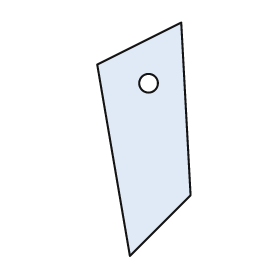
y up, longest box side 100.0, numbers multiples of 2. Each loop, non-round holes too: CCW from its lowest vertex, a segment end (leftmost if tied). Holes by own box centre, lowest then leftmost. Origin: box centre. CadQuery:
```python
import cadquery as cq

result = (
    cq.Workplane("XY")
    .moveTo(-6.0, -50.0)
    .lineTo(20.0, -24.0)
    .lineTo(16.0, 50.0)
    .lineTo(-20.0, 32.0)
    .close()
    .moveTo(2.0, 24.0)
    .circle(4.0)
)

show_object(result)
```